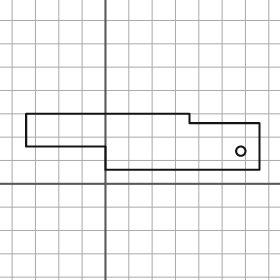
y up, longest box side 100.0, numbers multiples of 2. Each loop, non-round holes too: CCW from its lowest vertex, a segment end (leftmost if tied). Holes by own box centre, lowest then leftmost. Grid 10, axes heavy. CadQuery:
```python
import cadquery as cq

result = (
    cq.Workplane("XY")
    .moveTo(0.0, 6.0)
    .lineTo(66.0, 6.0)
    .lineTo(66.0, 26.0)
    .lineTo(36.0, 26.0)
    .lineTo(36.0, 30.0)
    .lineTo(-34.0, 30.0)
    .lineTo(-34.0, 16.0)
    .lineTo(0.0, 16.0)
    .close()
    .moveTo(58.0, 14.0)
    .circle(2.0)
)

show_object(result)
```